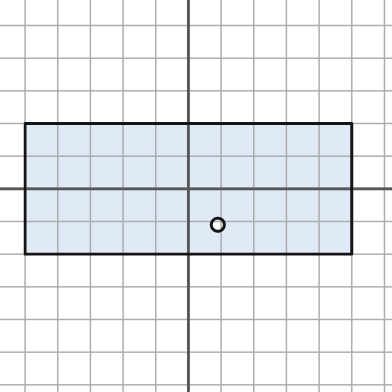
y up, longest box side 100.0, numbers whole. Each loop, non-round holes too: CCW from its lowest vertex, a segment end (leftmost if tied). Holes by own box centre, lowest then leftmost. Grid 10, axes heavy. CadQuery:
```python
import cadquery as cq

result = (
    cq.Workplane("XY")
    .moveTo(-50.0, -20.0)
    .lineTo(50.0, -20.0)
    .lineTo(50.0, 20.0)
    .lineTo(-50.0, 20.0)
    .close()
    .moveTo(9.0, -11.0)
    .circle(2.0)
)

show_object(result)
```